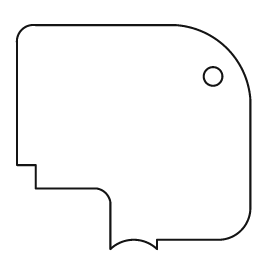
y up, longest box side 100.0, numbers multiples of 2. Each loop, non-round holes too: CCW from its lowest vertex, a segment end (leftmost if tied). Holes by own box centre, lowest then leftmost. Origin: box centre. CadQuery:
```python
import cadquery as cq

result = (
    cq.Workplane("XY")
    .moveTo(-10.0, -48.0)
    .threePointArc((0.0, -44.0), (10.0, -48.0))
    .lineTo(10.0, -44.0)
    .lineTo(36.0, -44.0)
    .threePointArc((46.0, -40.0), (50.0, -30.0))
    .lineTo(50.0, 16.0)
    .threePointArc((40.0, 38.0), (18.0, 48.0))
    .lineTo(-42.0, 48.0)
    .threePointArc((-48.0, 46.0), (-50.0, 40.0))
    .lineTo(-50.0, -12.0)
    .lineTo(-42.0, -12.0)
    .lineTo(-42.0, -22.0)
    .lineTo(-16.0, -22.0)
    .threePointArc((-12.0, -24.0), (-10.0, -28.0))
    .close()
    .moveTo(34.0, 26.0)
    .circle(4.0)
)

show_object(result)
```